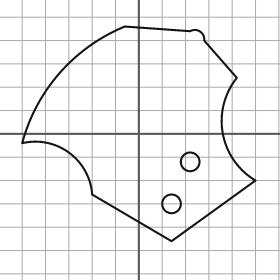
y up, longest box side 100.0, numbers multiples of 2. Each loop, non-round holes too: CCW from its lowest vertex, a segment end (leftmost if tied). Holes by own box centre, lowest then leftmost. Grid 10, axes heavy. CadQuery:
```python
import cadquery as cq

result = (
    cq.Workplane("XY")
    .moveTo(14.0, -46.0)
    .lineTo(50.0, -20.0)
    .threePointArc((36.0, 0.0), (42.0, 24.0))
    .lineTo(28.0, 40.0)
    .threePointArc((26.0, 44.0), (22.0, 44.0))
    .lineTo(-6.0, 46.0)
    .threePointArc((-34.0, 26.0), (-50.0, -4.0))
    .threePointArc((-30.0, -8.0), (-20.0, -26.0))
    .close()
    .moveTo(14.0, -30.0)
    .circle(4.0)
    .moveTo(22.0, -12.0)
    .circle(4.0)
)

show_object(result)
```